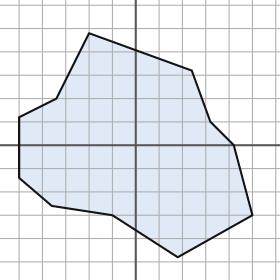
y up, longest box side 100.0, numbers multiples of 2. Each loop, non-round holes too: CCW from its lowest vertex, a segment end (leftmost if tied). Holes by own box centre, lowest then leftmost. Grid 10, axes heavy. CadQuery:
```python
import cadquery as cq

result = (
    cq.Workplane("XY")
    .moveTo(18.0, -48.0)
    .lineTo(50.0, -30.0)
    .lineTo(42.0, 0.0)
    .lineTo(32.0, 10.0)
    .lineTo(24.0, 32.0)
    .lineTo(-20.0, 48.0)
    .lineTo(-34.0, 20.0)
    .lineTo(-50.0, 12.0)
    .lineTo(-50.0, -14.0)
    .lineTo(-36.0, -26.0)
    .lineTo(-10.0, -30.0)
    .close()
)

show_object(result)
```